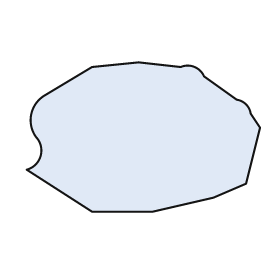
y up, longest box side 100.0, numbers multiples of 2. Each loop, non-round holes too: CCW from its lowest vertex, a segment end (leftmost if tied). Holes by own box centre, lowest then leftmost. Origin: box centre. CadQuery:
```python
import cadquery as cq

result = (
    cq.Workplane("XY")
    .moveTo(-22.0, -32.0)
    .lineTo(4.0, -32.0)
    .lineTo(30.0, -26.0)
    .lineTo(44.0, -20.0)
    .lineTo(50.0, 4.0)
    .lineTo(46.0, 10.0)
    .threePointArc((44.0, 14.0), (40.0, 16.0))
    .lineTo(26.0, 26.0)
    .threePointArc((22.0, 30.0), (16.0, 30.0))
    .lineTo(-2.0, 32.0)
    .lineTo(-22.0, 30.0)
    .lineTo(-42.0, 18.0)
    .threePointArc((-48.0, 10.0), (-46.0, 0.0))
    .threePointArc((-44.0, -8.0), (-50.0, -14.0))
    .close()
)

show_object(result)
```